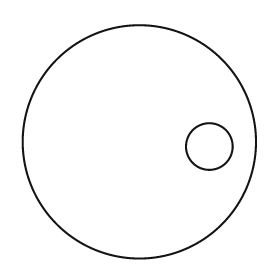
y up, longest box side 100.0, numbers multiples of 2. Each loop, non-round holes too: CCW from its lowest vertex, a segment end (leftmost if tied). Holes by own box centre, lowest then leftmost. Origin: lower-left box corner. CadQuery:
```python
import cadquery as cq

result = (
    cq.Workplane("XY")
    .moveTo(50.0, 50.0)
    .circle(50.0)
    .moveTo(80.0, 48.0)
    .circle(10.0)
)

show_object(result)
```